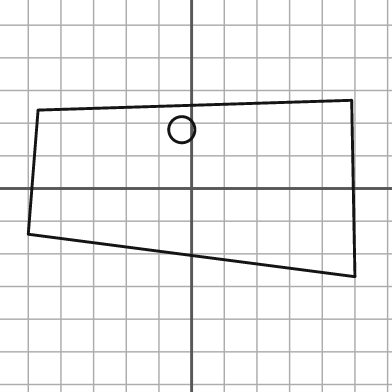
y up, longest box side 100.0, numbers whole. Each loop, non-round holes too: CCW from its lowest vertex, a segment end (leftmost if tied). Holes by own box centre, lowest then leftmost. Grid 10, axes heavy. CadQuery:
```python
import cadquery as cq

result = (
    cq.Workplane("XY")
    .moveTo(50.0, -27.0)
    .lineTo(49.0, 27.0)
    .lineTo(-47.0, 24.0)
    .lineTo(-50.0, -14.0)
    .close()
    .moveTo(-3.0, 18.0)
    .circle(4.0)
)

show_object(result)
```